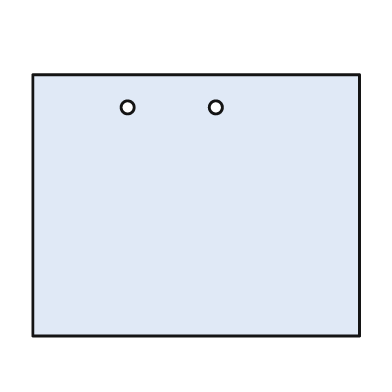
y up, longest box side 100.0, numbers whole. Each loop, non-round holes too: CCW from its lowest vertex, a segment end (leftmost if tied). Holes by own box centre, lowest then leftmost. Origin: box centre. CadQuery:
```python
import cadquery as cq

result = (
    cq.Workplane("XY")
    .moveTo(-50.0, -40.0)
    .lineTo(50.0, -40.0)
    .lineTo(50.0, 40.0)
    .lineTo(-50.0, 40.0)
    .close()
    .moveTo(-21.0, 30.0)
    .circle(2.0)
    .moveTo(6.0, 30.0)
    .circle(2.0)
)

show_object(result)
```